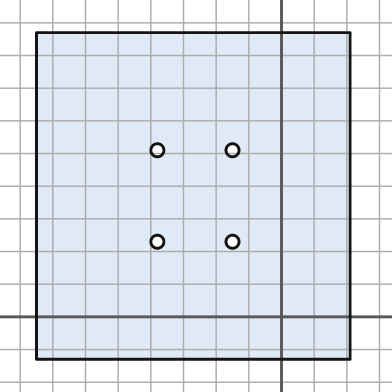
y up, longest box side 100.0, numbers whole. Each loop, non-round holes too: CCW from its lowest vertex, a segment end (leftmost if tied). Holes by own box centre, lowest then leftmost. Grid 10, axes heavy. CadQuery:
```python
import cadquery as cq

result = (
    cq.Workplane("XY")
    .moveTo(-75.0, -13.0)
    .lineTo(21.0, -13.0)
    .lineTo(21.0, 87.0)
    .lineTo(-75.0, 87.0)
    .close()
    .moveTo(-38.0, 23.0)
    .circle(2.0)
    .moveTo(-15.0, 23.0)
    .circle(2.0)
    .moveTo(-38.0, 51.0)
    .circle(2.0)
    .moveTo(-15.0, 51.0)
    .circle(2.0)
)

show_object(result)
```